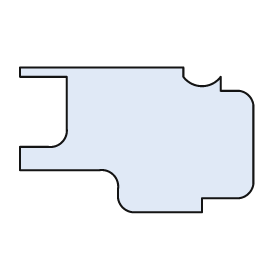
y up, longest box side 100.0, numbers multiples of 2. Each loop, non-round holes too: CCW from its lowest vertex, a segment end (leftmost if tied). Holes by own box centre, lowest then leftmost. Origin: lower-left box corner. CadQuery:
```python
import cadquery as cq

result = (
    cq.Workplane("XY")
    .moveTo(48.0, 0.0)
    .lineTo(78.0, 0.0)
    .lineTo(78.0, 6.0)
    .lineTo(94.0, 6.0)
    .threePointArc((98.0, 8.0), (100.0, 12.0))
    .lineTo(100.0, 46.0)
    .threePointArc((98.0, 50.0), (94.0, 52.0))
    .lineTo(86.0, 52.0)
    .lineTo(86.0, 58.0)
    .threePointArc((78.0, 54.0), (70.0, 58.0))
    .lineTo(70.0, 62.0)
    .lineTo(0.0, 62.0)
    .lineTo(0.0, 58.0)
    .lineTo(20.0, 58.0)
    .lineTo(20.0, 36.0)
    .threePointArc((18.0, 30.0), (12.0, 28.0))
    .lineTo(0.0, 28.0)
    .lineTo(0.0, 18.0)
    .lineTo(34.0, 18.0)
    .threePointArc((40.0, 16.0), (42.0, 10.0))
    .lineTo(42.0, 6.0)
    .threePointArc((44.0, 2.0), (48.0, 0.0))
    .close()
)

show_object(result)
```